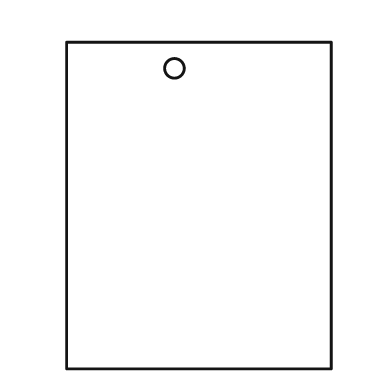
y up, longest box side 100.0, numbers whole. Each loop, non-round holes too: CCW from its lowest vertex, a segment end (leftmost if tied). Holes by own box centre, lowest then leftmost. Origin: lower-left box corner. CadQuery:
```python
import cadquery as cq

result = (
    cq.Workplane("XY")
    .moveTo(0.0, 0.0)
    .lineTo(81.0, 0.0)
    .lineTo(81.0, 100.0)
    .lineTo(0.0, 100.0)
    .close()
    .moveTo(33.0, 92.0)
    .circle(3.0)
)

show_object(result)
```